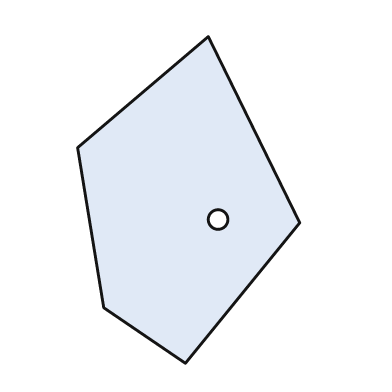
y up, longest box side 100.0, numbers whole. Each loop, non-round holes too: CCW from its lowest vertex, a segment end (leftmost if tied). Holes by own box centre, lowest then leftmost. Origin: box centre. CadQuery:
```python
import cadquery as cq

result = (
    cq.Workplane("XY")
    .moveTo(-1.0, -50.0)
    .lineTo(34.0, -7.0)
    .lineTo(6.0, 50.0)
    .lineTo(-34.0, 16.0)
    .lineTo(-26.0, -33.0)
    .close()
    .moveTo(9.0, -6.0)
    .circle(3.0)
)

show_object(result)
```